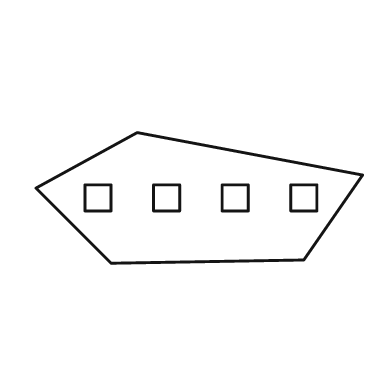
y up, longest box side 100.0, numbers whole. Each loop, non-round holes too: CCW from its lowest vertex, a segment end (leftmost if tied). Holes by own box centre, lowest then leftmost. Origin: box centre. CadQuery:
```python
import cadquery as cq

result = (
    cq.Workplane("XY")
    .moveTo(-27.0, -20.0)
    .lineTo(32.0, -19.0)
    .lineTo(50.0, 7.0)
    .lineTo(-19.0, 20.0)
    .lineTo(-50.0, 3.0)
    .close()
    .moveTo(-35.0, -4.0)
    .lineTo(-27.0, -4.0)
    .lineTo(-27.0, 4.0)
    .lineTo(-35.0, 4.0)
    .close()
    .moveTo(-14.0, -4.0)
    .lineTo(-6.0, -4.0)
    .lineTo(-6.0, 4.0)
    .lineTo(-14.0, 4.0)
    .close()
    .moveTo(7.0, -4.0)
    .lineTo(15.0, -4.0)
    .lineTo(15.0, 4.0)
    .lineTo(7.0, 4.0)
    .close()
    .moveTo(28.0, -4.0)
    .lineTo(36.0, -4.0)
    .lineTo(36.0, 4.0)
    .lineTo(28.0, 4.0)
    .close()
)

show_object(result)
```